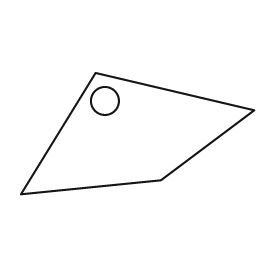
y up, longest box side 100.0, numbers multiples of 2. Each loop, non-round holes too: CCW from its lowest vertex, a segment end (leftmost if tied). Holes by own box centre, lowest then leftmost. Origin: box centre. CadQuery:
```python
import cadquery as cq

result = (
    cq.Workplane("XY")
    .moveTo(-50.0, -26.0)
    .lineTo(10.0, -20.0)
    .lineTo(50.0, 10.0)
    .lineTo(-18.0, 26.0)
    .close()
    .moveTo(-14.0, 14.0)
    .circle(6.0)
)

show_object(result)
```